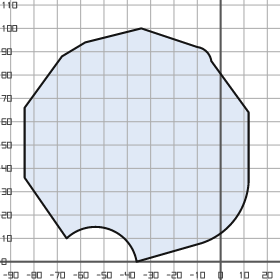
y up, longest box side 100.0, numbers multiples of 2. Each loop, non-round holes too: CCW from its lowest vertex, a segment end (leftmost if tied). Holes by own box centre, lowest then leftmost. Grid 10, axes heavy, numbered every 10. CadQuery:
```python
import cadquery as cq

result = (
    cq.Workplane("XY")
    .moveTo(-36.0, 0.0)
    .lineTo(-8.0, 8.0)
    .threePointArc((6.0, 18.0), (12.0, 34.0))
    .lineTo(12.0, 64.0)
    .lineTo(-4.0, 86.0)
    .threePointArc((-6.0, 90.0), (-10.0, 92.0))
    .lineTo(-34.0, 100.0)
    .lineTo(-58.0, 94.0)
    .lineTo(-68.0, 88.0)
    .lineTo(-84.0, 66.0)
    .lineTo(-84.0, 36.0)
    .lineTo(-66.0, 10.0)
    .threePointArc((-48.0, 14.0), (-36.0, 0.0))
    .close()
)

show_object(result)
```